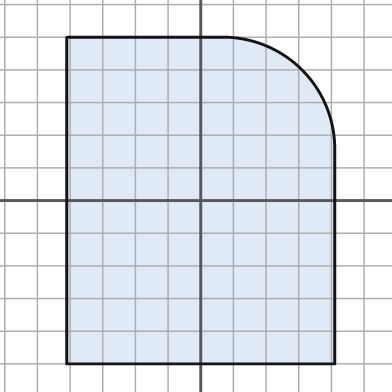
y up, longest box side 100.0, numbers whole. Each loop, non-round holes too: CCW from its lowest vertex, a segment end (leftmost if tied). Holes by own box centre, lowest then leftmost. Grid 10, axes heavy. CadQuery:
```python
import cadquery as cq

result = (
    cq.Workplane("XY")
    .moveTo(-41.0, -50.0)
    .lineTo(41.0, -50.0)
    .lineTo(41.0, 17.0)
    .threePointArc((31.0, 40.0), (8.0, 50.0))
    .lineTo(-41.0, 50.0)
    .close()
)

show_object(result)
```